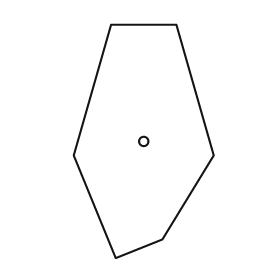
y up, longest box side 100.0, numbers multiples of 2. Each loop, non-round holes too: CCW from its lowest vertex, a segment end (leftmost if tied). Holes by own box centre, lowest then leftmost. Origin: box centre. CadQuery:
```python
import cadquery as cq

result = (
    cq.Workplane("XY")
    .moveTo(-12.0, -50.0)
    .lineTo(8.0, -42.0)
    .lineTo(30.0, -6.0)
    .lineTo(14.0, 50.0)
    .lineTo(-14.0, 50.0)
    .lineTo(-30.0, -6.0)
    .close()
    .moveTo(0.0, 0.0)
    .circle(2.0)
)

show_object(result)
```